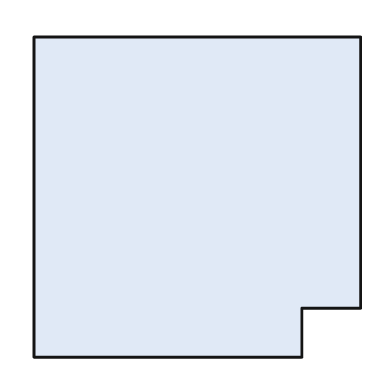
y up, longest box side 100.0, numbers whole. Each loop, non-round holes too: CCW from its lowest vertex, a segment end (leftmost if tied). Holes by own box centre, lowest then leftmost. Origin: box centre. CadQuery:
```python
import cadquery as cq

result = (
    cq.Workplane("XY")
    .moveTo(-50.0, -49.0)
    .lineTo(32.0, -49.0)
    .lineTo(32.0, -34.0)
    .lineTo(50.0, -34.0)
    .lineTo(50.0, 49.0)
    .lineTo(-50.0, 49.0)
    .close()
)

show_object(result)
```